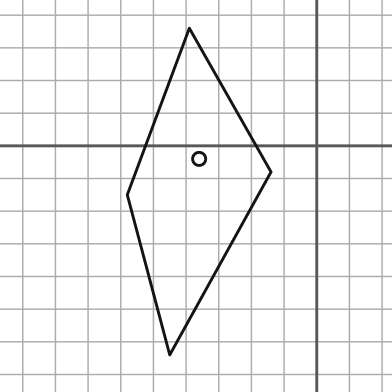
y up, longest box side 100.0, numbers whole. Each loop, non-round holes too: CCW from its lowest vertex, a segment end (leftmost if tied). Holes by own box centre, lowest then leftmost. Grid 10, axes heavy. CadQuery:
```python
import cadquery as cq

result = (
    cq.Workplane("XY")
    .moveTo(-45.0, -64.0)
    .lineTo(-14.0, -8.0)
    .lineTo(-39.0, 36.0)
    .lineTo(-58.0, -15.0)
    .close()
    .moveTo(-36.0, -4.0)
    .circle(2.0)
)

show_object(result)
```